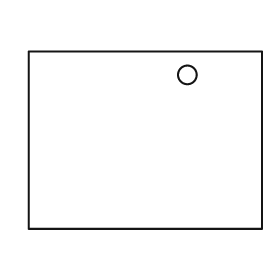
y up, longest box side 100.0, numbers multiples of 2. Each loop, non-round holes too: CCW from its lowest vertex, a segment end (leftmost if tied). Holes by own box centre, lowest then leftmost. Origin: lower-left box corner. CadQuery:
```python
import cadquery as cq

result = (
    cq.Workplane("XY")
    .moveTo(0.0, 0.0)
    .lineTo(100.0, 0.0)
    .lineTo(100.0, 76.0)
    .lineTo(0.0, 76.0)
    .close()
    .moveTo(68.0, 66.0)
    .circle(4.0)
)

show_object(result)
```